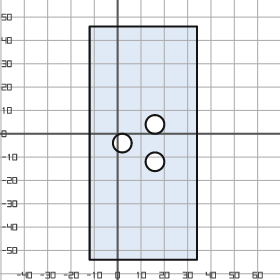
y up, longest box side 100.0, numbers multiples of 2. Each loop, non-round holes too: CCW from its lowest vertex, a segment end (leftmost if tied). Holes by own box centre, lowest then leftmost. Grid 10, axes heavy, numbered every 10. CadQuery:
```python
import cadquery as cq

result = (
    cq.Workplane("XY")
    .moveTo(-12.0, -54.0)
    .lineTo(34.0, -54.0)
    .lineTo(34.0, 46.0)
    .lineTo(-12.0, 46.0)
    .close()
    .moveTo(16.0, -12.0)
    .circle(4.0)
    .moveTo(2.0, -4.0)
    .circle(4.0)
    .moveTo(16.0, 4.0)
    .circle(4.0)
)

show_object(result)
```